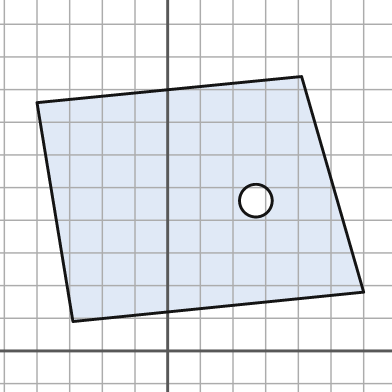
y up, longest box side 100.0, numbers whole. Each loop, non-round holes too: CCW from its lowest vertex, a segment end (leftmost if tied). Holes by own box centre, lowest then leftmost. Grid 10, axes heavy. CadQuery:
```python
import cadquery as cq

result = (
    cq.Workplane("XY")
    .moveTo(-29.0, 9.0)
    .lineTo(60.0, 18.0)
    .lineTo(41.0, 84.0)
    .lineTo(-40.0, 76.0)
    .close()
    .moveTo(27.0, 46.0)
    .circle(5.0)
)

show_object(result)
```